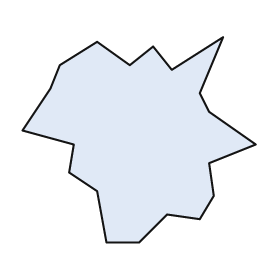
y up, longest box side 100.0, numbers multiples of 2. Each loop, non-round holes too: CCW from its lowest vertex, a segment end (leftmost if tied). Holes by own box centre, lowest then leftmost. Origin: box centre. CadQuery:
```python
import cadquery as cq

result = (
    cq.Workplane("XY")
    .moveTo(-14.0, -44.0)
    .lineTo(0.0, -44.0)
    .lineTo(12.0, -32.0)
    .lineTo(26.0, -34.0)
    .lineTo(32.0, -24.0)
    .lineTo(30.0, -10.0)
    .lineTo(50.0, -2.0)
    .lineTo(30.0, 12.0)
    .lineTo(26.0, 20.0)
    .lineTo(36.0, 44.0)
    .lineTo(14.0, 30.0)
    .lineTo(6.0, 40.0)
    .lineTo(-4.0, 32.0)
    .lineTo(-18.0, 42.0)
    .lineTo(-34.0, 32.0)
    .lineTo(-38.0, 22.0)
    .lineTo(-50.0, 4.0)
    .lineTo(-28.0, -2.0)
    .lineTo(-30.0, -14.0)
    .lineTo(-18.0, -22.0)
    .close()
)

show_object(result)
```